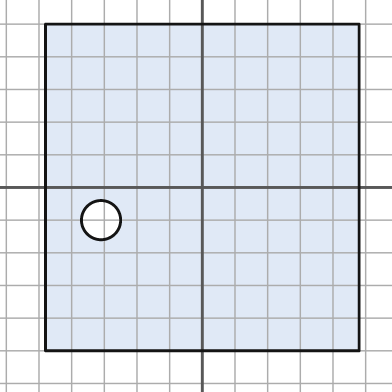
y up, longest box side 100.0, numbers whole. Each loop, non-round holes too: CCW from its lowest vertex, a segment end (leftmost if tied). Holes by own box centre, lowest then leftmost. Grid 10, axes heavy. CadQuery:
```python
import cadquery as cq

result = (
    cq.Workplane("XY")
    .moveTo(-48.0, -50.0)
    .lineTo(48.0, -50.0)
    .lineTo(48.0, 50.0)
    .lineTo(-48.0, 50.0)
    .close()
    .moveTo(-31.0, -10.0)
    .circle(6.0)
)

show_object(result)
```